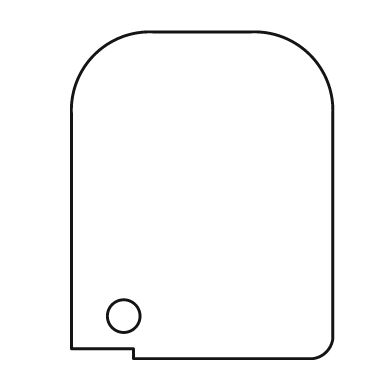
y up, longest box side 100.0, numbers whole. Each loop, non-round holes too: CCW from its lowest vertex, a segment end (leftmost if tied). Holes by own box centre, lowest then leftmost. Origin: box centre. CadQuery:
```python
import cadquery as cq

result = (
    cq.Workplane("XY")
    .moveTo(-21.0, -50.0)
    .lineTo(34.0, -50.0)
    .threePointArc((38.0, -48.0), (40.0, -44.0))
    .lineTo(40.0, 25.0)
    .threePointArc((33.0, 43.0), (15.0, 50.0))
    .lineTo(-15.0, 50.0)
    .threePointArc((-33.0, 43.0), (-40.0, 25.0))
    .lineTo(-40.0, -47.0)
    .lineTo(-21.0, -47.0)
    .close()
    .moveTo(-24.0, -37.0)
    .circle(5.0)
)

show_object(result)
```